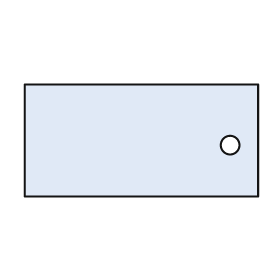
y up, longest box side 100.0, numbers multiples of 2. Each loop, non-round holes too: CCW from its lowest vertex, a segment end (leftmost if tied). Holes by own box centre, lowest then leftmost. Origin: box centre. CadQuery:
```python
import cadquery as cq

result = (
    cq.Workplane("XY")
    .moveTo(-50.0, -24.0)
    .lineTo(50.0, -24.0)
    .lineTo(50.0, 24.0)
    .lineTo(-50.0, 24.0)
    .close()
    .moveTo(38.0, -2.0)
    .circle(4.0)
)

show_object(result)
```